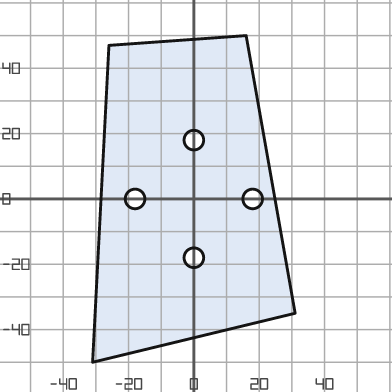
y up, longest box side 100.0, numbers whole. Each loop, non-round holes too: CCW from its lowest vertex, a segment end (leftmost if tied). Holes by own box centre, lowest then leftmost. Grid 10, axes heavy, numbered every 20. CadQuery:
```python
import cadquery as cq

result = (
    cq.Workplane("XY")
    .moveTo(-31.0, -50.0)
    .lineTo(31.0, -35.0)
    .lineTo(16.0, 50.0)
    .lineTo(-26.0, 47.0)
    .close()
    .moveTo(0.0, -18.0)
    .circle(3.0)
    .moveTo(-18.0, 0.0)
    .circle(3.0)
    .moveTo(18.0, 0.0)
    .circle(3.0)
    .moveTo(0.0, 18.0)
    .circle(3.0)
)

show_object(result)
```